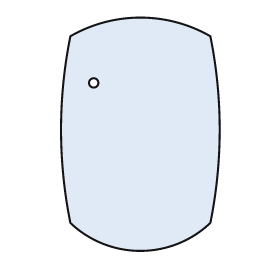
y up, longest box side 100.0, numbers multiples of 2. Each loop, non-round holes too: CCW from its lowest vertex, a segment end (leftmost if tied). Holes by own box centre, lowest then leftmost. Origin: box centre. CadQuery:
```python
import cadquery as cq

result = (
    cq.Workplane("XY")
    .moveTo(-30.0, -38.0)
    .threePointArc((0.0, -50.0), (30.0, -38.0))
    .threePointArc((34.0, 2.0), (30.0, 42.0))
    .threePointArc((0.0, 50.0), (-30.0, 42.0))
    .threePointArc((-34.0, 2.0), (-30.0, -38.0))
    .close()
    .moveTo(-20.0, 22.0)
    .circle(2.0)
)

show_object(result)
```